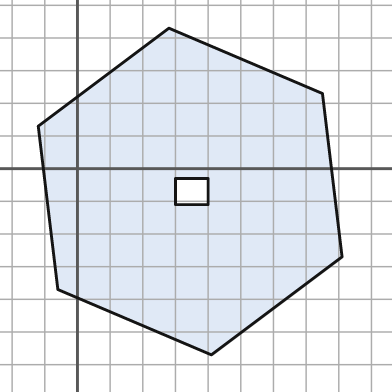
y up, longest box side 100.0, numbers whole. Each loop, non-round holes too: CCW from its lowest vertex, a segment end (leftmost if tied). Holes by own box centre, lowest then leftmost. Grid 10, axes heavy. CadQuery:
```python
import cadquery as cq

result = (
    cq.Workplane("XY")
    .moveTo(41.0, -57.0)
    .lineTo(81.0, -27.0)
    .lineTo(75.0, 23.0)
    .lineTo(28.0, 43.0)
    .lineTo(-12.0, 13.0)
    .lineTo(-6.0, -37.0)
    .close()
    .moveTo(30.0, -11.0)
    .lineTo(40.0, -11.0)
    .lineTo(40.0, -3.0)
    .lineTo(30.0, -3.0)
    .close()
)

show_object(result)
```